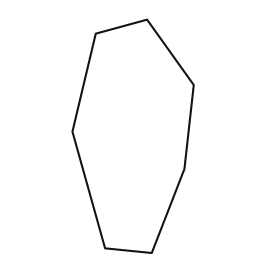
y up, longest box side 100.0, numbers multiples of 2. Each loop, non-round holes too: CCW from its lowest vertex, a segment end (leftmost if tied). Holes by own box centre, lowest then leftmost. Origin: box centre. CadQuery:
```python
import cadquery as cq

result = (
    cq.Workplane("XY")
    .moveTo(8.0, -50.0)
    .lineTo(22.0, -14.0)
    .lineTo(26.0, 22.0)
    .lineTo(6.0, 50.0)
    .lineTo(-16.0, 44.0)
    .lineTo(-26.0, 2.0)
    .lineTo(-12.0, -48.0)
    .close()
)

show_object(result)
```